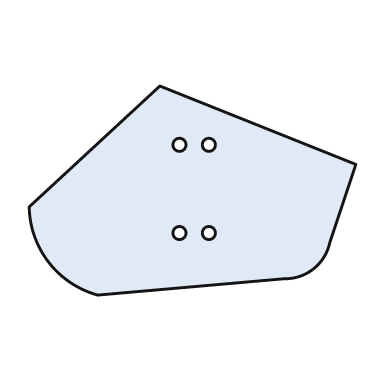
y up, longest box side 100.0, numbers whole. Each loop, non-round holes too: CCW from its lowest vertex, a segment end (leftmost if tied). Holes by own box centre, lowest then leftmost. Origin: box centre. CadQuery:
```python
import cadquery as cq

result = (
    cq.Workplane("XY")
    .moveTo(-29.0, -32.0)
    .lineTo(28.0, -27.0)
    .threePointArc((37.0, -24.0), (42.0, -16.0))
    .lineTo(50.0, 8.0)
    .lineTo(-10.0, 32.0)
    .lineTo(-50.0, -5.0)
    .threePointArc((-44.0, -22.0), (-29.0, -32.0))
    .close()
    .moveTo(-4.0, -13.0)
    .circle(2.0)
    .moveTo(5.0, -13.0)
    .circle(2.0)
    .moveTo(-4.0, 14.0)
    .circle(2.0)
    .moveTo(5.0, 14.0)
    .circle(2.0)
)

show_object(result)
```